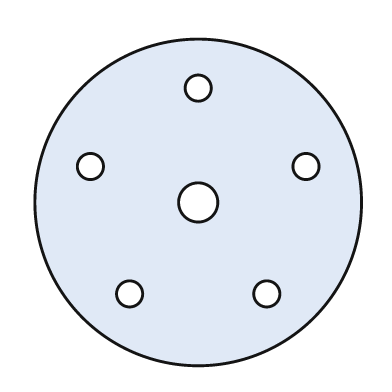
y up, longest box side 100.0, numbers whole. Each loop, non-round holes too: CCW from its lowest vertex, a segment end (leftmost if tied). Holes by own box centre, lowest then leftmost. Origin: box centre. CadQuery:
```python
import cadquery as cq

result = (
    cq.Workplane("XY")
    .moveTo(0.0, 0.0)
    .circle(50.0)
    .moveTo(-21.0, -28.0)
    .circle(4.0)
    .moveTo(21.0, -28.0)
    .circle(4.0)
    .moveTo(0.0, 0.0)
    .circle(6.0)
    .moveTo(-33.0, 11.0)
    .circle(4.0)
    .moveTo(33.0, 11.0)
    .circle(4.0)
    .moveTo(0.0, 35.0)
    .circle(4.0)
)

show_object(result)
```